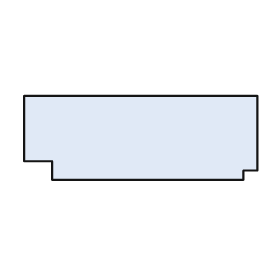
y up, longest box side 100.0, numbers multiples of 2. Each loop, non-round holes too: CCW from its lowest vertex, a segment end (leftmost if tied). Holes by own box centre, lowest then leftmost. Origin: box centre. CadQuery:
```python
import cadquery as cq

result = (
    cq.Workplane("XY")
    .moveTo(-38.0, -18.0)
    .lineTo(44.0, -18.0)
    .lineTo(44.0, -14.0)
    .lineTo(50.0, -14.0)
    .lineTo(50.0, 18.0)
    .lineTo(-50.0, 18.0)
    .lineTo(-50.0, -10.0)
    .lineTo(-38.0, -10.0)
    .close()
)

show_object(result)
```